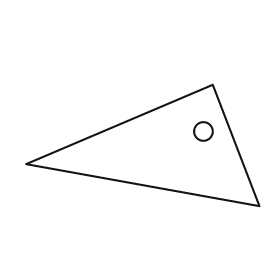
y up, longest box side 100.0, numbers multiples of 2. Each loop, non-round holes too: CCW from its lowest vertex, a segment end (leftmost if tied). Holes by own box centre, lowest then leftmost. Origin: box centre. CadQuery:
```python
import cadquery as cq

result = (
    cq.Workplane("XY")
    .moveTo(50.0, -26.0)
    .lineTo(30.0, 26.0)
    .lineTo(-50.0, -8.0)
    .close()
    .moveTo(26.0, 6.0)
    .circle(4.0)
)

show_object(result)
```